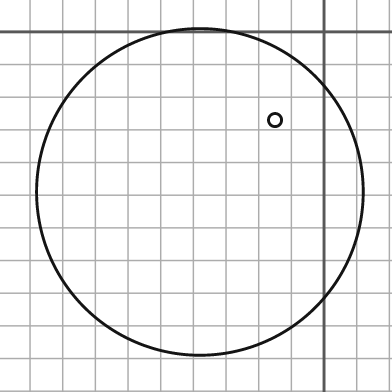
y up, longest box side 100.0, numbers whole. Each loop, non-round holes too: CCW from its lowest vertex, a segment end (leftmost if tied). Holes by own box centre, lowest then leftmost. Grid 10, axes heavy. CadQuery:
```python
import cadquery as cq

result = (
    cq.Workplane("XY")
    .moveTo(-38.0, -49.0)
    .circle(50.0)
    .moveTo(-15.0, -27.0)
    .circle(2.0)
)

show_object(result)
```